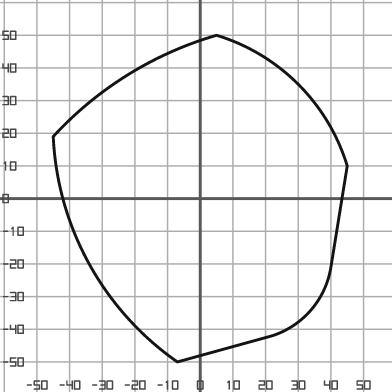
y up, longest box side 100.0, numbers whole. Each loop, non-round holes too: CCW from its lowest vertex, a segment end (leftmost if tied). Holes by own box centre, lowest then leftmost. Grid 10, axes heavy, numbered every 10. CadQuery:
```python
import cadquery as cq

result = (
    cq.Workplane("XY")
    .moveTo(-7.0, -50.0)
    .lineTo(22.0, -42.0)
    .threePointArc((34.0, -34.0), (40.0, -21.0))
    .lineTo(45.0, 10.0)
    .threePointArc((30.0, 35.0), (5.0, 50.0))
    .threePointArc((-22.0, 38.0), (-45.0, 19.0))
    .threePointArc((-34.0, -20.0), (-7.0, -50.0))
    .close()
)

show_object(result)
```